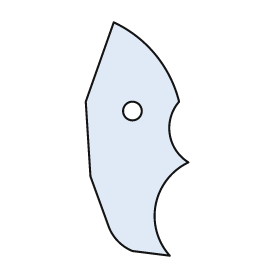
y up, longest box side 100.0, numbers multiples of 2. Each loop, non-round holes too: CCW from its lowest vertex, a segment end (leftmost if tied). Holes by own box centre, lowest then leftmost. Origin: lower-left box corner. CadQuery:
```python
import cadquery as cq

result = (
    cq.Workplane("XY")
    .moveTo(36.0, 0.0)
    .threePointArc((30.0, 22.0), (44.0, 40.0))
    .threePointArc((36.0, 52.0), (40.0, 66.0))
    .threePointArc((30.0, 86.0), (12.0, 100.0))
    .lineTo(0.0, 66.0)
    .lineTo(2.0, 34.0)
    .lineTo(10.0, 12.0)
    .threePointArc((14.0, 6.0), (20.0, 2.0))
    .close()
    .moveTo(20.0, 62.0)
    .circle(4.0)
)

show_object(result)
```